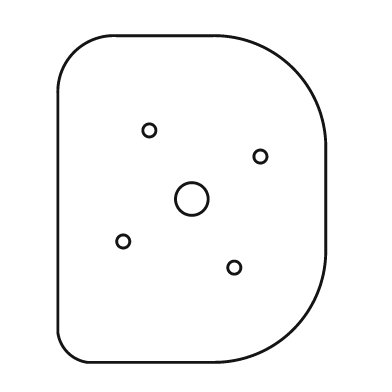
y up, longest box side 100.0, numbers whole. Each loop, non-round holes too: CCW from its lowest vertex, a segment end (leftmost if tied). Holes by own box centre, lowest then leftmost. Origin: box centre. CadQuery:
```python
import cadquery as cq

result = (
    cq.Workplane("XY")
    .moveTo(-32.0, -50.0)
    .lineTo(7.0, -50.0)
    .threePointArc((31.0, -40.0), (41.0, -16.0))
    .lineTo(41.0, 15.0)
    .threePointArc((31.0, 40.0), (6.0, 50.0))
    .lineTo(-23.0, 50.0)
    .threePointArc((-36.0, 45.0), (-41.0, 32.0))
    .lineTo(-41.0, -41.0)
    .threePointArc((-38.0, -47.0), (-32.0, -50.0))
    .close()
    .moveTo(13.0, -21.0)
    .circle(2.0)
    .moveTo(-21.0, -13.0)
    .circle(2.0)
    .moveTo(0.0, 0.0)
    .circle(5.0)
    .moveTo(21.0, 13.0)
    .circle(2.0)
    .moveTo(-13.0, 21.0)
    .circle(2.0)
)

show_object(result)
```